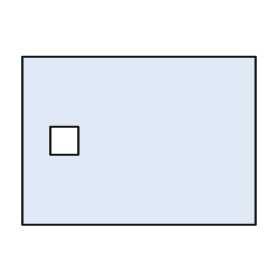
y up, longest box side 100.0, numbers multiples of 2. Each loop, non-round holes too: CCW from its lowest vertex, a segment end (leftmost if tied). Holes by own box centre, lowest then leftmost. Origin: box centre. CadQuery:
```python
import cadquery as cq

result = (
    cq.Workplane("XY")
    .moveTo(-50.0, -36.0)
    .lineTo(50.0, -36.0)
    .lineTo(50.0, 36.0)
    .lineTo(-50.0, 36.0)
    .close()
    .moveTo(-38.0, -6.0)
    .lineTo(-26.0, -6.0)
    .lineTo(-26.0, 6.0)
    .lineTo(-38.0, 6.0)
    .close()
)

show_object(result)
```